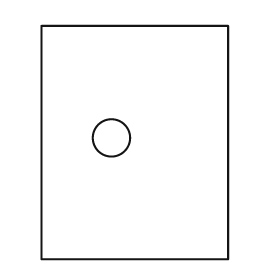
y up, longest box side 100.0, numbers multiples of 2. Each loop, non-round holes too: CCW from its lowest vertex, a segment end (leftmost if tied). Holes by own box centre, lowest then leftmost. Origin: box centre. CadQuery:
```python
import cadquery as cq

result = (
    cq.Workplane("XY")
    .moveTo(-40.0, -50.0)
    .lineTo(40.0, -50.0)
    .lineTo(40.0, 50.0)
    .lineTo(-40.0, 50.0)
    .close()
    .moveTo(-10.0, 2.0)
    .circle(8.0)
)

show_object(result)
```